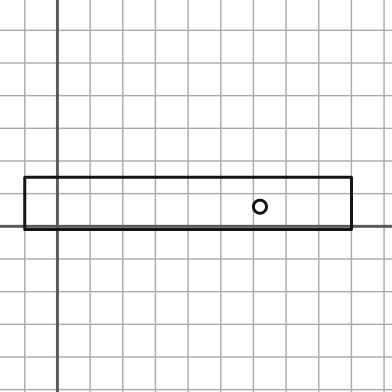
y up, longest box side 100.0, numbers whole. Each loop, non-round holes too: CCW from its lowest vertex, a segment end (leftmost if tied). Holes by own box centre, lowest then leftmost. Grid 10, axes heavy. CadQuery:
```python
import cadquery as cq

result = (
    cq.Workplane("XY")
    .moveTo(-10.0, -1.0)
    .lineTo(90.0, -1.0)
    .lineTo(90.0, 15.0)
    .lineTo(-10.0, 15.0)
    .close()
    .moveTo(62.0, 6.0)
    .circle(2.0)
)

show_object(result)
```